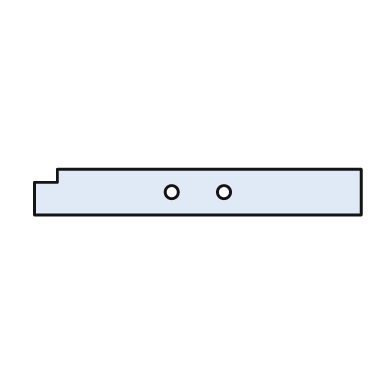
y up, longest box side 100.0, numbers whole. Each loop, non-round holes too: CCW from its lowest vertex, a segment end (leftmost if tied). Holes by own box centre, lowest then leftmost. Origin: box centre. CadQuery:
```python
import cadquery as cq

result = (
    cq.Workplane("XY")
    .moveTo(-50.0, -7.0)
    .lineTo(50.0, -7.0)
    .lineTo(50.0, 7.0)
    .lineTo(-43.0, 7.0)
    .lineTo(-43.0, 3.0)
    .lineTo(-50.0, 3.0)
    .close()
    .moveTo(-8.0, 0.0)
    .circle(2.0)
    .moveTo(8.0, 0.0)
    .circle(2.0)
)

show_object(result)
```